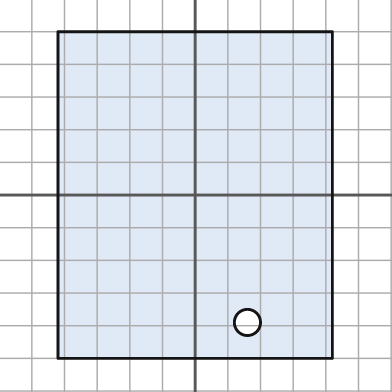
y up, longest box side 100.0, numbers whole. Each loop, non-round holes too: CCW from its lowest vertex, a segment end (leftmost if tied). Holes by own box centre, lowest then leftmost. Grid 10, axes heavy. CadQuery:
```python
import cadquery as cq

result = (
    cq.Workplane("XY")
    .moveTo(-42.0, -50.0)
    .lineTo(42.0, -50.0)
    .lineTo(42.0, 50.0)
    .lineTo(-42.0, 50.0)
    .close()
    .moveTo(16.0, -39.0)
    .circle(4.0)
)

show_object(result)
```